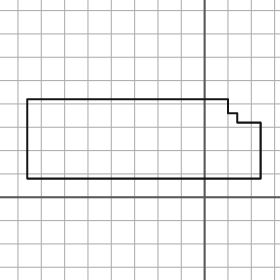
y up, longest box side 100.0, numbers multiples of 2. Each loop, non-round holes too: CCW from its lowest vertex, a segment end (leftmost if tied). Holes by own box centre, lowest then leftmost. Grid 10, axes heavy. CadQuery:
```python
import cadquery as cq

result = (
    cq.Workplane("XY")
    .moveTo(-76.0, 8.0)
    .lineTo(24.0, 8.0)
    .lineTo(24.0, 32.0)
    .lineTo(14.0, 32.0)
    .lineTo(14.0, 36.0)
    .lineTo(10.0, 36.0)
    .lineTo(10.0, 42.0)
    .lineTo(-76.0, 42.0)
    .close()
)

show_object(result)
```